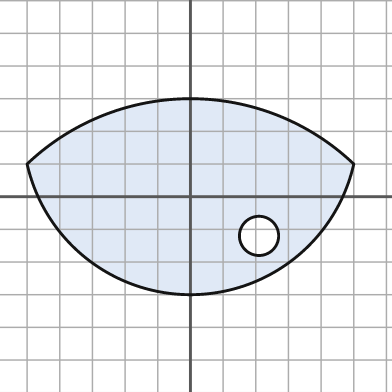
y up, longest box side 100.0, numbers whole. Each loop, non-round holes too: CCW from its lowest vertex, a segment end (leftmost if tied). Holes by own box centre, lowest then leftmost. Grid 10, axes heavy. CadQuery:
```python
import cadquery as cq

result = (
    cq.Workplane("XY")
    .moveTo(-50.0, 10.0)
    .threePointArc((0.0, -30.0), (50.0, 10.0))
    .threePointArc((0.0, 30.0), (-50.0, 10.0))
    .close()
    .moveTo(21.0, -12.0)
    .circle(6.0)
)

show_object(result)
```